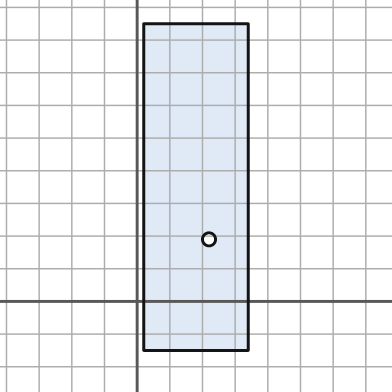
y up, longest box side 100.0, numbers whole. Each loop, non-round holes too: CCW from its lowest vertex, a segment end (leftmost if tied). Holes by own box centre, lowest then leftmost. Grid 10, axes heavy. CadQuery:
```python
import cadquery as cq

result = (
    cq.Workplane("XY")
    .moveTo(2.0, -15.0)
    .lineTo(34.0, -15.0)
    .lineTo(34.0, 85.0)
    .lineTo(2.0, 85.0)
    .close()
    .moveTo(22.0, 19.0)
    .circle(2.0)
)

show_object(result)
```